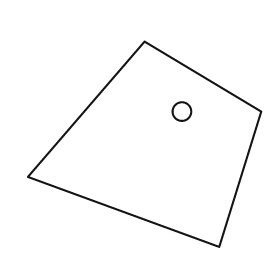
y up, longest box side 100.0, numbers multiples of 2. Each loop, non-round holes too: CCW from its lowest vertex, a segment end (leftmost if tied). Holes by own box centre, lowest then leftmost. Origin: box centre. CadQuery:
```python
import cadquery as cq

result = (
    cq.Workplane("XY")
    .moveTo(32.0, -44.0)
    .lineTo(50.0, 14.0)
    .lineTo(0.0, 44.0)
    .lineTo(-50.0, -14.0)
    .close()
    .moveTo(16.0, 14.0)
    .circle(4.0)
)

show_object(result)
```